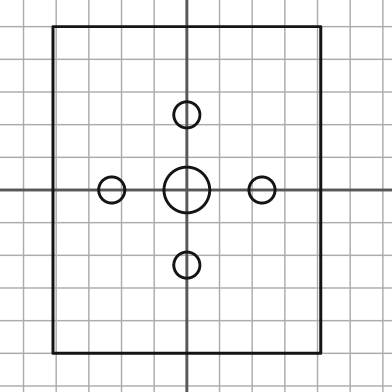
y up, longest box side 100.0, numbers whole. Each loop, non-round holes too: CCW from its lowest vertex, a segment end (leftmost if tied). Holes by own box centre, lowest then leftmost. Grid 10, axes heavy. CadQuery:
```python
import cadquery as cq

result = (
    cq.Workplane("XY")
    .moveTo(-41.0, -50.0)
    .lineTo(41.0, -50.0)
    .lineTo(41.0, 50.0)
    .lineTo(-41.0, 50.0)
    .close()
    .moveTo(0.0, -23.0)
    .circle(4.0)
    .moveTo(-23.0, 0.0)
    .circle(4.0)
    .moveTo(0.0, 0.0)
    .circle(7.0)
    .moveTo(23.0, 0.0)
    .circle(4.0)
    .moveTo(0.0, 23.0)
    .circle(4.0)
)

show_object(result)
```